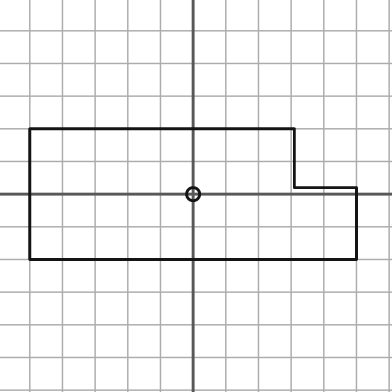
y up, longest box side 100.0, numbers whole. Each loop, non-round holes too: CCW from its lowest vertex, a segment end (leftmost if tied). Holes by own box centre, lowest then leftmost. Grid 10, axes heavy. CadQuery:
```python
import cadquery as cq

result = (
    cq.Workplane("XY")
    .moveTo(-50.0, -20.0)
    .lineTo(50.0, -20.0)
    .lineTo(50.0, 2.0)
    .lineTo(31.0, 2.0)
    .lineTo(31.0, 20.0)
    .lineTo(-50.0, 20.0)
    .close()
    .moveTo(0.0, 0.0)
    .circle(2.0)
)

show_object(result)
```